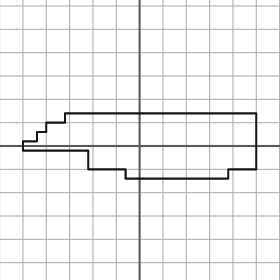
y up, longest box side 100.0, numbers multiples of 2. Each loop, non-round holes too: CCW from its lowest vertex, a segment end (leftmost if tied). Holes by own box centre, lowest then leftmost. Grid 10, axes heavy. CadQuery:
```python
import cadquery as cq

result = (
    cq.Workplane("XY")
    .moveTo(-6.0, -14.0)
    .lineTo(38.0, -14.0)
    .lineTo(38.0, -10.0)
    .lineTo(50.0, -10.0)
    .lineTo(50.0, 14.0)
    .lineTo(-32.0, 14.0)
    .lineTo(-32.0, 10.0)
    .lineTo(-40.0, 10.0)
    .lineTo(-40.0, 6.0)
    .lineTo(-44.0, 6.0)
    .lineTo(-44.0, 2.0)
    .lineTo(-50.0, 2.0)
    .lineTo(-50.0, -2.0)
    .lineTo(-22.0, -2.0)
    .lineTo(-22.0, -10.0)
    .lineTo(-6.0, -10.0)
    .close()
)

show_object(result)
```